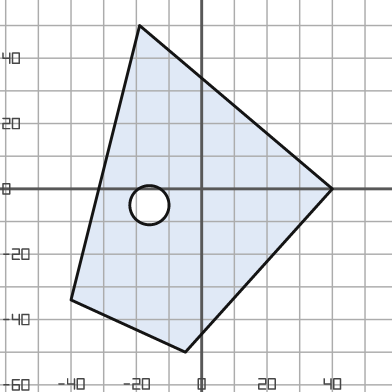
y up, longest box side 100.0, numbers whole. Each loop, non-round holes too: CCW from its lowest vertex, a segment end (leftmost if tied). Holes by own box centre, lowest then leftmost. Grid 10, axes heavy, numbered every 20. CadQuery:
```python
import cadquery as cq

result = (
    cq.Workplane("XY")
    .moveTo(-5.0, -50.0)
    .lineTo(40.0, 0.0)
    .lineTo(-19.0, 50.0)
    .lineTo(-40.0, -34.0)
    .close()
    .moveTo(-16.0, -5.0)
    .circle(6.0)
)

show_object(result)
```